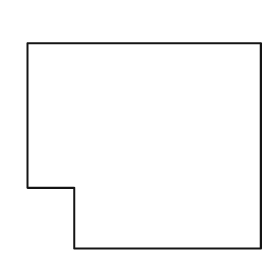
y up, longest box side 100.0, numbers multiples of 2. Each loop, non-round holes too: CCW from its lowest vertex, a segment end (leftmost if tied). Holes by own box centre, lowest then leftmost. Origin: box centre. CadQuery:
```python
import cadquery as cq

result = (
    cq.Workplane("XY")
    .moveTo(-30.0, -44.0)
    .lineTo(50.0, -44.0)
    .lineTo(50.0, 44.0)
    .lineTo(-50.0, 44.0)
    .lineTo(-50.0, -18.0)
    .lineTo(-30.0, -18.0)
    .close()
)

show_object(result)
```